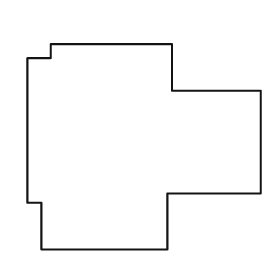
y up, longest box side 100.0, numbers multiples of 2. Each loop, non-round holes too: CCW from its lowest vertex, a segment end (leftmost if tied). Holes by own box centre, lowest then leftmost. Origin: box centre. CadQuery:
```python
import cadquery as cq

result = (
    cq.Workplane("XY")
    .moveTo(-44.0, -44.0)
    .lineTo(10.0, -44.0)
    .lineTo(10.0, -20.0)
    .lineTo(50.0, -20.0)
    .lineTo(50.0, 24.0)
    .lineTo(12.0, 24.0)
    .lineTo(12.0, 44.0)
    .lineTo(-40.0, 44.0)
    .lineTo(-40.0, 38.0)
    .lineTo(-50.0, 38.0)
    .lineTo(-50.0, -24.0)
    .lineTo(-44.0, -24.0)
    .close()
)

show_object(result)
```